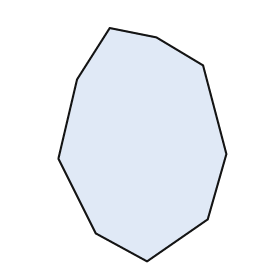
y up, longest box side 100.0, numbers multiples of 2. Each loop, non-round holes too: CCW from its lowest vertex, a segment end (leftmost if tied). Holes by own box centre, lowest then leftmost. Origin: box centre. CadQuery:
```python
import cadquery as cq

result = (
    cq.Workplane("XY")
    .moveTo(2.0, -50.0)
    .lineTo(28.0, -32.0)
    .lineTo(36.0, -4.0)
    .lineTo(26.0, 34.0)
    .lineTo(6.0, 46.0)
    .lineTo(-14.0, 50.0)
    .lineTo(-28.0, 28.0)
    .lineTo(-36.0, -6.0)
    .lineTo(-20.0, -38.0)
    .close()
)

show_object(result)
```